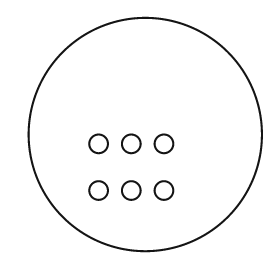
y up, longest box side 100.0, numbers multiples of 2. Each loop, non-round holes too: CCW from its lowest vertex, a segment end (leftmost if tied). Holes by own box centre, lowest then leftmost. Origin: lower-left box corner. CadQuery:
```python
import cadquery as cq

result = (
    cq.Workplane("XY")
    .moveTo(50.0, 50.0)
    .circle(50.0)
    .moveTo(30.0, 26.0)
    .circle(4.0)
    .moveTo(44.0, 26.0)
    .circle(4.0)
    .moveTo(58.0, 26.0)
    .circle(4.0)
    .moveTo(30.0, 46.0)
    .circle(4.0)
    .moveTo(44.0, 46.0)
    .circle(4.0)
    .moveTo(58.0, 46.0)
    .circle(4.0)
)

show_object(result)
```